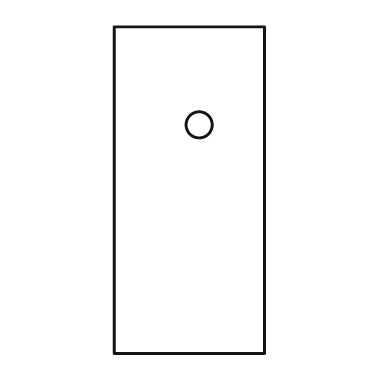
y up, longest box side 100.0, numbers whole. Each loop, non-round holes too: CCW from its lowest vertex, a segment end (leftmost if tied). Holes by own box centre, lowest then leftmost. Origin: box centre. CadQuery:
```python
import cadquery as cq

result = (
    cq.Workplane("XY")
    .moveTo(-23.0, -50.0)
    .lineTo(23.0, -50.0)
    .lineTo(23.0, 50.0)
    .lineTo(-23.0, 50.0)
    .close()
    .moveTo(3.0, 20.0)
    .circle(4.0)
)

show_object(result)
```